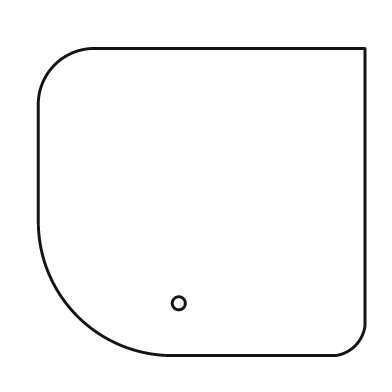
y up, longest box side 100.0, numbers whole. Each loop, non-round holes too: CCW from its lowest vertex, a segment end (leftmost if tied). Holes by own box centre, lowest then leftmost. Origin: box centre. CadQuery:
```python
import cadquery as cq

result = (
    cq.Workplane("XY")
    .moveTo(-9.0, -47.0)
    .lineTo(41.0, -47.0)
    .threePointArc((47.0, -44.0), (50.0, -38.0))
    .lineTo(50.0, 47.0)
    .lineTo(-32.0, 47.0)
    .threePointArc((-45.0, 42.0), (-50.0, 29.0))
    .lineTo(-50.0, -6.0)
    .threePointArc((-38.0, -35.0), (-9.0, -47.0))
    .close()
    .moveTo(-7.0, -31.0)
    .circle(2.0)
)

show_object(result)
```